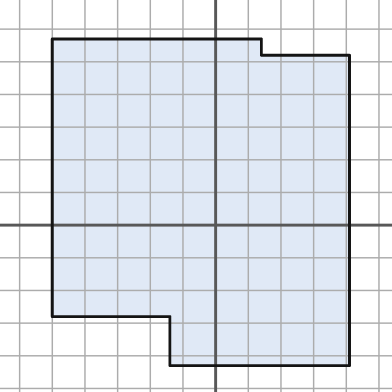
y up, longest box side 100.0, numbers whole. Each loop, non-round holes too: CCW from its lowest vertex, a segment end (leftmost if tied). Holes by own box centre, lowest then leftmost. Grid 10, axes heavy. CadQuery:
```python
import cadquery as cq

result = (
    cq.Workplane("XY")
    .moveTo(-14.0, -43.0)
    .lineTo(41.0, -43.0)
    .lineTo(41.0, 52.0)
    .lineTo(14.0, 52.0)
    .lineTo(14.0, 57.0)
    .lineTo(-50.0, 57.0)
    .lineTo(-50.0, -28.0)
    .lineTo(-14.0, -28.0)
    .close()
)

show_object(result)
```